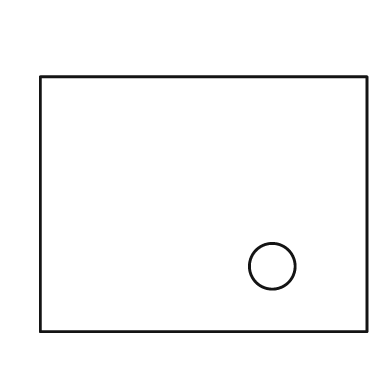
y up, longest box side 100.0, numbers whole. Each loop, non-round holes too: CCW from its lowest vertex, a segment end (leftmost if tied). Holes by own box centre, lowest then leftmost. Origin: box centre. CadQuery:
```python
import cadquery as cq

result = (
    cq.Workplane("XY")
    .moveTo(-50.0, -39.0)
    .lineTo(50.0, -39.0)
    .lineTo(50.0, 39.0)
    .lineTo(-50.0, 39.0)
    .close()
    .moveTo(21.0, -19.0)
    .circle(7.0)
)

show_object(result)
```